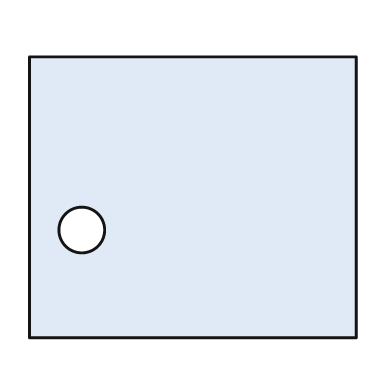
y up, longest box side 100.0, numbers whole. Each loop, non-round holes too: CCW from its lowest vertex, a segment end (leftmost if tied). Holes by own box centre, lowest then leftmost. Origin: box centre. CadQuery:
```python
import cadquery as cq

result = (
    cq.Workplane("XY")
    .moveTo(-50.0, -43.0)
    .lineTo(50.0, -43.0)
    .lineTo(50.0, 43.0)
    .lineTo(-50.0, 43.0)
    .close()
    .moveTo(-34.0, -10.0)
    .circle(7.0)
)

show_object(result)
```